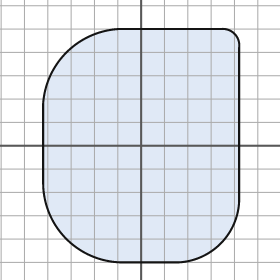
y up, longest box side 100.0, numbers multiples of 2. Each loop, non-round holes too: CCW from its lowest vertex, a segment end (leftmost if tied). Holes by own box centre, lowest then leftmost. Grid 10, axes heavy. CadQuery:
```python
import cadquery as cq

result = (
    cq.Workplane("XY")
    .moveTo(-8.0, -50.0)
    .lineTo(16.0, -50.0)
    .threePointArc((34.0, -42.0), (42.0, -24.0))
    .lineTo(42.0, 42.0)
    .threePointArc((40.0, 48.0), (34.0, 50.0))
    .lineTo(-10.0, 50.0)
    .threePointArc((-32.0, 40.0), (-42.0, 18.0))
    .lineTo(-42.0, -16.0)
    .threePointArc((-32.0, -40.0), (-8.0, -50.0))
    .close()
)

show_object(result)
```